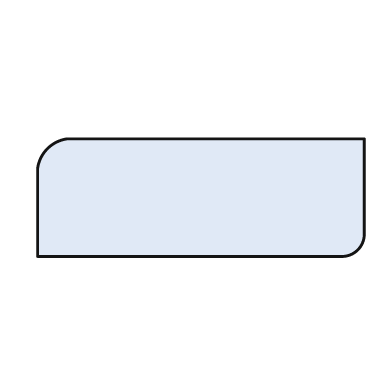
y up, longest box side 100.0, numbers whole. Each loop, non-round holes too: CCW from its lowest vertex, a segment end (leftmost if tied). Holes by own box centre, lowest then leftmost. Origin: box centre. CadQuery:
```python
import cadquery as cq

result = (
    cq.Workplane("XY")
    .moveTo(-50.0, -18.0)
    .lineTo(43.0, -18.0)
    .threePointArc((48.0, -16.0), (50.0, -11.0))
    .lineTo(50.0, 18.0)
    .lineTo(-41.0, 18.0)
    .threePointArc((-47.0, 15.0), (-50.0, 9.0))
    .close()
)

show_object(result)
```